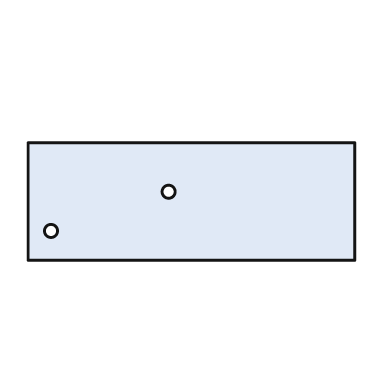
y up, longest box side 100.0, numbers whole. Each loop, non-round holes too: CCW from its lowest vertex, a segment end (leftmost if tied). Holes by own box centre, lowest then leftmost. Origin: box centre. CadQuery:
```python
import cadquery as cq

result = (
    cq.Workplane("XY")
    .moveTo(-50.0, -18.0)
    .lineTo(50.0, -18.0)
    .lineTo(50.0, 18.0)
    .lineTo(-50.0, 18.0)
    .close()
    .moveTo(-43.0, -9.0)
    .circle(2.0)
    .moveTo(-7.0, 3.0)
    .circle(2.0)
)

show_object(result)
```